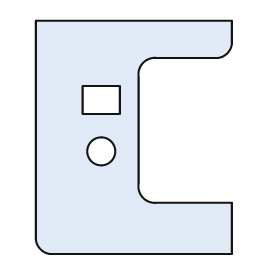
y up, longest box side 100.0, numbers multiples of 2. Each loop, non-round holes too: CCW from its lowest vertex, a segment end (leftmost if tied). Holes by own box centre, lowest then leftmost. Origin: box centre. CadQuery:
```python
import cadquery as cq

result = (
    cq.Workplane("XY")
    .moveTo(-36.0, -50.0)
    .lineTo(42.0, -50.0)
    .lineTo(42.0, -28.0)
    .lineTo(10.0, -28.0)
    .threePointArc((4.0, -26.0), (2.0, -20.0))
    .lineTo(2.0, 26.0)
    .threePointArc((4.0, 32.0), (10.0, 34.0))
    .lineTo(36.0, 34.0)
    .threePointArc((40.0, 36.0), (42.0, 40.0))
    .lineTo(42.0, 50.0)
    .lineTo(-42.0, 50.0)
    .lineTo(-42.0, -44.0)
    .threePointArc((-40.0, -48.0), (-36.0, -50.0))
    .close()
    .moveTo(-14.0, -6.0)
    .circle(6.0)
    .moveTo(-22.0, 10.0)
    .lineTo(-6.0, 10.0)
    .lineTo(-6.0, 22.0)
    .lineTo(-22.0, 22.0)
    .close()
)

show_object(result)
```